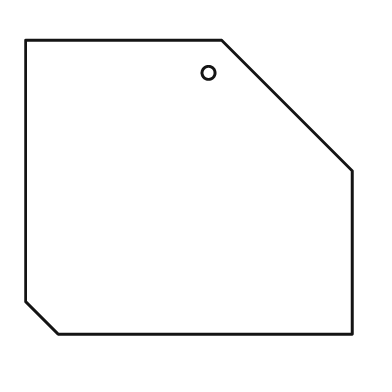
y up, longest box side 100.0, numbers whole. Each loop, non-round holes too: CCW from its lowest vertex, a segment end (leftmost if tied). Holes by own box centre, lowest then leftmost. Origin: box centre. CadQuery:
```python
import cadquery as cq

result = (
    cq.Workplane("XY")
    .moveTo(-40.0, -45.0)
    .lineTo(50.0, -45.0)
    .lineTo(50.0, 5.0)
    .lineTo(10.0, 45.0)
    .lineTo(-50.0, 45.0)
    .lineTo(-50.0, -35.0)
    .close()
    .moveTo(6.0, 35.0)
    .circle(2.0)
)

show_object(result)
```